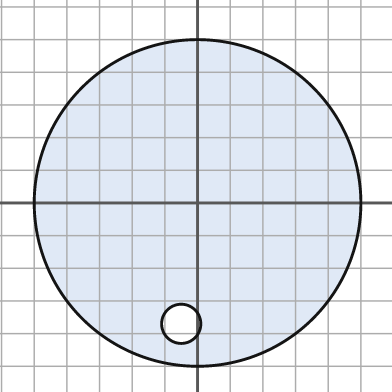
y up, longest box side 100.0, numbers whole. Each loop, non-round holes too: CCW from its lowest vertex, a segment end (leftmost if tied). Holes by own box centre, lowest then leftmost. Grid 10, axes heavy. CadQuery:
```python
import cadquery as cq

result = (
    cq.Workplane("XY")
    .moveTo(0.0, 0.0)
    .circle(50.0)
    .moveTo(-5.0, -37.0)
    .circle(6.0)
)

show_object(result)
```